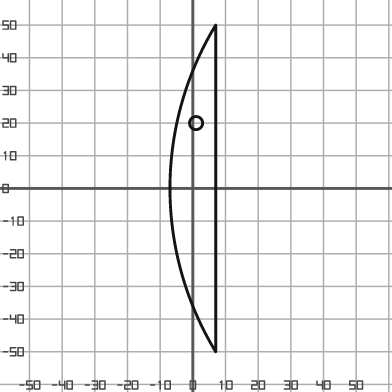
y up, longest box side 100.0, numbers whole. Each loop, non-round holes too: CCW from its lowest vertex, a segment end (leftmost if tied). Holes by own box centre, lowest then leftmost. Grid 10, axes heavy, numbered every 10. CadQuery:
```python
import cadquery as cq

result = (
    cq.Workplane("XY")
    .moveTo(7.0, -50.0)
    .lineTo(7.0, 50.0)
    .threePointArc((-7.0, 0.0), (7.0, -50.0))
    .close()
    .moveTo(1.0, 20.0)
    .circle(2.0)
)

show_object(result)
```